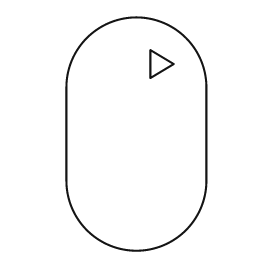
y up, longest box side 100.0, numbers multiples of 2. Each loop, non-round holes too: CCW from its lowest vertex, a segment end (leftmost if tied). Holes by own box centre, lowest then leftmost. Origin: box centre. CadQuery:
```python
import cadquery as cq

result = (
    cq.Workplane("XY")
    .moveTo(-30.0, -20.0)
    .threePointArc((0.0, -50.0), (30.0, -20.0))
    .lineTo(30.0, 20.0)
    .threePointArc((0.0, 50.0), (-30.0, 20.0))
    .close()
    .moveTo(6.0, 24.0)
    .lineTo(16.0, 30.0)
    .lineTo(6.0, 36.0)
    .close()
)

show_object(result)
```